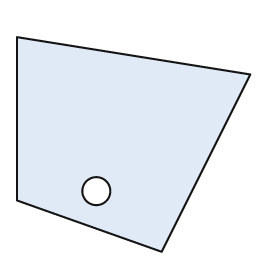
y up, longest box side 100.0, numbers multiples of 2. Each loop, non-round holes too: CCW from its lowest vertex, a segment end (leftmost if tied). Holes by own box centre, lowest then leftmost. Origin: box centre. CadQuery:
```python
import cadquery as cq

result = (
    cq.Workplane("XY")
    .moveTo(12.0, -46.0)
    .lineTo(50.0, 30.0)
    .lineTo(-50.0, 46.0)
    .lineTo(-50.0, -24.0)
    .close()
    .moveTo(-16.0, -20.0)
    .circle(6.0)
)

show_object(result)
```